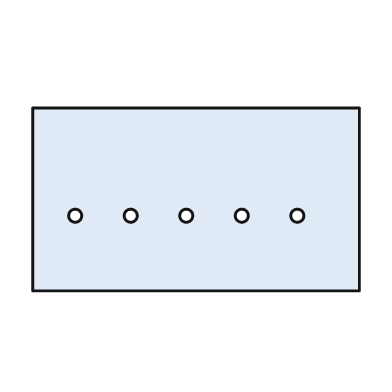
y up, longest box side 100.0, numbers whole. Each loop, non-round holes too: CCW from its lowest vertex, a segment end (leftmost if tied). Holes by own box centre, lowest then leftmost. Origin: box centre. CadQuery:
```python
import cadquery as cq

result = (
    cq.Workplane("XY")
    .moveTo(-50.0, -28.0)
    .lineTo(50.0, -28.0)
    .lineTo(50.0, 28.0)
    .lineTo(-50.0, 28.0)
    .close()
    .moveTo(-37.0, -5.0)
    .circle(2.0)
    .moveTo(-20.0, -5.0)
    .circle(2.0)
    .moveTo(-3.0, -5.0)
    .circle(2.0)
    .moveTo(14.0, -5.0)
    .circle(2.0)
    .moveTo(31.0, -5.0)
    .circle(2.0)
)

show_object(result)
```